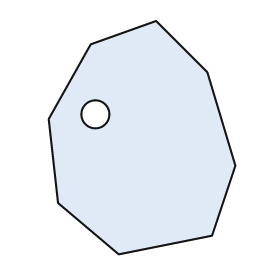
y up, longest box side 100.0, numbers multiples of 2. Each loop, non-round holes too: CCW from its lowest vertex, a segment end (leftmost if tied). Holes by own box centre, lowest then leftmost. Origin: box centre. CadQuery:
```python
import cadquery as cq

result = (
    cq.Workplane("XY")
    .moveTo(-10.0, -50.0)
    .lineTo(30.0, -42.0)
    .lineTo(40.0, -12.0)
    .lineTo(28.0, 28.0)
    .lineTo(6.0, 50.0)
    .lineTo(-22.0, 40.0)
    .lineTo(-40.0, 8.0)
    .lineTo(-36.0, -28.0)
    .close()
    .moveTo(-20.0, 10.0)
    .circle(6.0)
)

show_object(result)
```